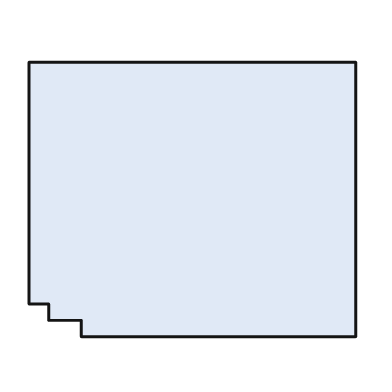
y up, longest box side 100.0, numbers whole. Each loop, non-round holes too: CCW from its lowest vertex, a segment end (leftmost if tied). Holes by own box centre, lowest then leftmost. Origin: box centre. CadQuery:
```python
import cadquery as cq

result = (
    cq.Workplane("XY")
    .moveTo(-34.0, -42.0)
    .lineTo(50.0, -42.0)
    .lineTo(50.0, 42.0)
    .lineTo(-50.0, 42.0)
    .lineTo(-50.0, -32.0)
    .lineTo(-44.0, -32.0)
    .lineTo(-44.0, -37.0)
    .lineTo(-34.0, -37.0)
    .close()
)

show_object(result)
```